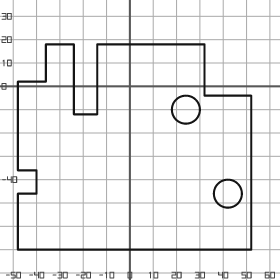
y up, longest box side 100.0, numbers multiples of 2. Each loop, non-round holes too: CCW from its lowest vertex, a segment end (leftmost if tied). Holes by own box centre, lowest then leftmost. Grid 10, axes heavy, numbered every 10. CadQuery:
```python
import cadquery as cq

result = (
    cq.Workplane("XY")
    .moveTo(-48.0, -70.0)
    .lineTo(52.0, -70.0)
    .lineTo(52.0, -4.0)
    .lineTo(32.0, -4.0)
    .lineTo(32.0, 18.0)
    .lineTo(-14.0, 18.0)
    .lineTo(-14.0, -12.0)
    .lineTo(-24.0, -12.0)
    .lineTo(-24.0, 18.0)
    .lineTo(-36.0, 18.0)
    .lineTo(-36.0, 2.0)
    .lineTo(-48.0, 2.0)
    .lineTo(-48.0, -36.0)
    .lineTo(-40.0, -36.0)
    .lineTo(-40.0, -46.0)
    .lineTo(-48.0, -46.0)
    .close()
    .moveTo(42.0, -46.0)
    .circle(6.0)
    .moveTo(24.0, -10.0)
    .circle(6.0)
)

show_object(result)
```